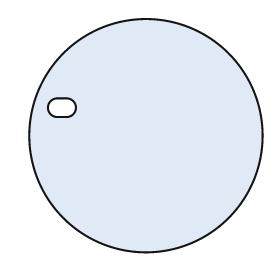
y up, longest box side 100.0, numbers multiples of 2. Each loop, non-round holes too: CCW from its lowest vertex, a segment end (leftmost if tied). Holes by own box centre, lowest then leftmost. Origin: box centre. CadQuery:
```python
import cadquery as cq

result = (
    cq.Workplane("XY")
    .moveTo(0.0, 0.0)
    .circle(50.0)
    .moveTo(-38.0, 8.0)
    .lineTo(-34.0, 8.0)
    .threePointArc((-30.0, 12.0), (-34.0, 16.0))
    .lineTo(-38.0, 16.0)
    .threePointArc((-42.0, 12.0), (-38.0, 8.0))
    .close()
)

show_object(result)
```